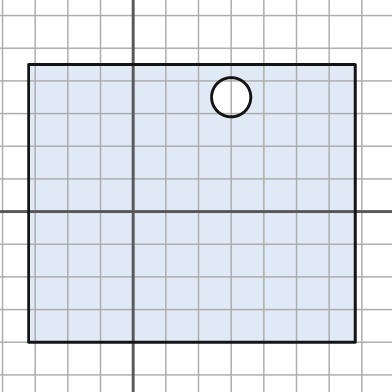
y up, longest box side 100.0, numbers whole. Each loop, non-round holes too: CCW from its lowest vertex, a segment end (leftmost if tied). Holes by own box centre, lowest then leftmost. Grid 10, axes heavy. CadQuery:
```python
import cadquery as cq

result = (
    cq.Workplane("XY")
    .moveTo(-32.0, -40.0)
    .lineTo(68.0, -40.0)
    .lineTo(68.0, 45.0)
    .lineTo(-32.0, 45.0)
    .close()
    .moveTo(30.0, 35.0)
    .circle(6.0)
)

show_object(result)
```